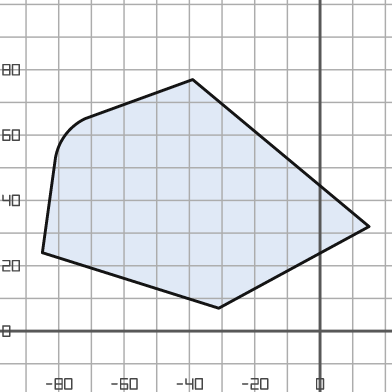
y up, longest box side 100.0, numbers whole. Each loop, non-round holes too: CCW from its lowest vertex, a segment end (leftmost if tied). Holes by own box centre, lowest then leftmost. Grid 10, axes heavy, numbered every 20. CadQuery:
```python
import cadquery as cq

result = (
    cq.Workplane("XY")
    .moveTo(-31.0, 7.0)
    .lineTo(15.0, 32.0)
    .lineTo(-39.0, 77.0)
    .lineTo(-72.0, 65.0)
    .threePointArc((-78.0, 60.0), (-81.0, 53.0))
    .lineTo(-85.0, 24.0)
    .close()
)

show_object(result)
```